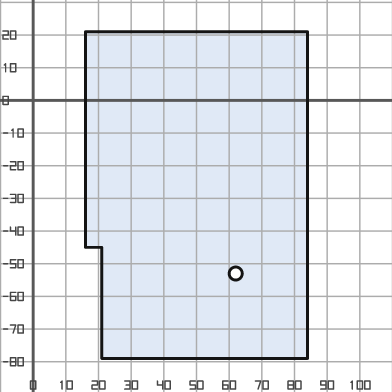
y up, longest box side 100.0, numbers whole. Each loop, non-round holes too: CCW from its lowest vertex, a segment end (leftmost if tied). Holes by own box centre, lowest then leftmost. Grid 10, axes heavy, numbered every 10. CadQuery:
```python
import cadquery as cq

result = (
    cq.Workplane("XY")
    .moveTo(21.0, -79.0)
    .lineTo(84.0, -79.0)
    .lineTo(84.0, 21.0)
    .lineTo(16.0, 21.0)
    .lineTo(16.0, -45.0)
    .lineTo(21.0, -45.0)
    .close()
    .moveTo(62.0, -53.0)
    .circle(2.0)
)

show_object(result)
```